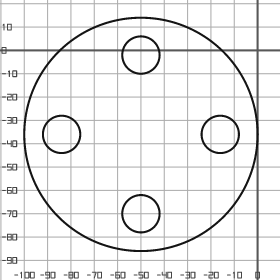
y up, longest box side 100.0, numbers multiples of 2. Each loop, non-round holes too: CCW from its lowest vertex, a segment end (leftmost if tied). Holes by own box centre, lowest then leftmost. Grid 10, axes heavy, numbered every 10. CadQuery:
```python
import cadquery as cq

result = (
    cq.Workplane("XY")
    .moveTo(-50.0, -36.0)
    .circle(50.0)
    .moveTo(-50.0, -70.0)
    .circle(8.0)
    .moveTo(-84.0, -36.0)
    .circle(8.0)
    .moveTo(-16.0, -36.0)
    .circle(8.0)
    .moveTo(-50.0, -2.0)
    .circle(8.0)
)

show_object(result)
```